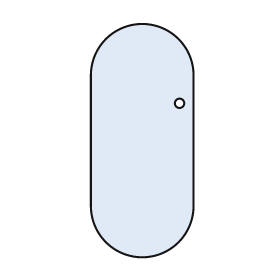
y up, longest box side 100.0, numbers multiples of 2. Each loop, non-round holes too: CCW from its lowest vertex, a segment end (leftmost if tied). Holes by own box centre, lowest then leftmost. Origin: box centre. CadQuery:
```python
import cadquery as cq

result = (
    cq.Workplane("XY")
    .moveTo(-22.0, -28.0)
    .threePointArc((0.0, -50.0), (22.0, -28.0))
    .lineTo(22.0, 28.0)
    .threePointArc((0.0, 50.0), (-22.0, 28.0))
    .close()
    .moveTo(16.0, 16.0)
    .circle(2.0)
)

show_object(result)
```